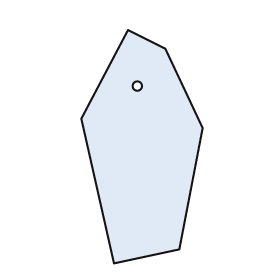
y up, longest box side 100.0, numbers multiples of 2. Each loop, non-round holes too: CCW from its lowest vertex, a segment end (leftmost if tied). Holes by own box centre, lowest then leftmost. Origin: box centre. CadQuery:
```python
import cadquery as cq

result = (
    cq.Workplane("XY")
    .moveTo(-12.0, -50.0)
    .lineTo(16.0, -44.0)
    .lineTo(26.0, 8.0)
    .lineTo(10.0, 42.0)
    .lineTo(-6.0, 50.0)
    .lineTo(-26.0, 12.0)
    .close()
    .moveTo(-2.0, 26.0)
    .circle(2.0)
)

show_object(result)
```